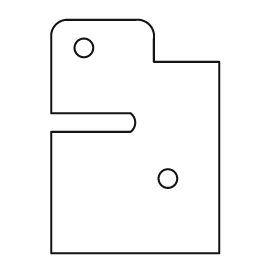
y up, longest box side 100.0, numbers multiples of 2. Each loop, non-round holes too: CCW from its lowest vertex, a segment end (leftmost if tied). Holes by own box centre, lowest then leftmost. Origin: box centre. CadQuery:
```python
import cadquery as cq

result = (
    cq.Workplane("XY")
    .moveTo(-36.0, -50.0)
    .lineTo(36.0, -50.0)
    .lineTo(36.0, 32.0)
    .lineTo(8.0, 32.0)
    .lineTo(8.0, 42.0)
    .threePointArc((6.0, 48.0), (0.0, 50.0))
    .lineTo(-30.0, 50.0)
    .threePointArc((-34.0, 48.0), (-36.0, 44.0))
    .lineTo(-36.0, 10.0)
    .lineTo(-2.0, 10.0)
    .threePointArc((0.0, 6.0), (-2.0, 2.0))
    .lineTo(-36.0, 2.0)
    .close()
    .moveTo(14.0, -18.0)
    .circle(4.0)
    .moveTo(-22.0, 38.0)
    .circle(4.0)
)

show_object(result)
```